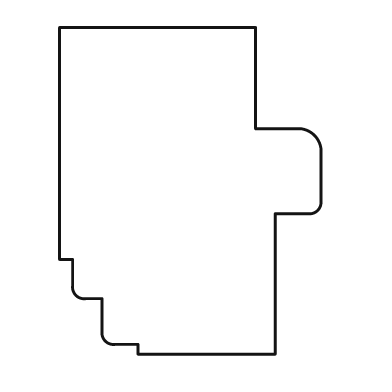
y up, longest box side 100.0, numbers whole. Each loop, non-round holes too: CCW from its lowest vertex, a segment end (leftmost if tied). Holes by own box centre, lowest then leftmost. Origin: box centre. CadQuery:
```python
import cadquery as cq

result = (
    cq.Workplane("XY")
    .moveTo(-16.0, -50.0)
    .lineTo(26.0, -50.0)
    .lineTo(26.0, -7.0)
    .lineTo(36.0, -7.0)
    .threePointArc((39.0, -6.0), (40.0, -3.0))
    .lineTo(40.0, 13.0)
    .threePointArc((38.0, 17.0), (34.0, 19.0))
    .lineTo(20.0, 19.0)
    .lineTo(20.0, 50.0)
    .lineTo(-40.0, 50.0)
    .lineTo(-40.0, -21.0)
    .lineTo(-36.0, -21.0)
    .lineTo(-36.0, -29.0)
    .threePointArc((-35.0, -32.0), (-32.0, -33.0))
    .lineTo(-27.0, -33.0)
    .lineTo(-27.0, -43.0)
    .threePointArc((-26.0, -46.0), (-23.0, -47.0))
    .lineTo(-16.0, -47.0)
    .close()
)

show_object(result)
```